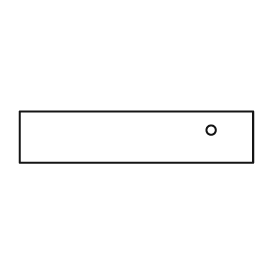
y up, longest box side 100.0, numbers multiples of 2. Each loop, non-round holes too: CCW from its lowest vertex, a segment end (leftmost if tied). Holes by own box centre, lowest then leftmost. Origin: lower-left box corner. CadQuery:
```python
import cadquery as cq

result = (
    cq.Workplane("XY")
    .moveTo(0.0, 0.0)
    .lineTo(100.0, 0.0)
    .lineTo(100.0, 22.0)
    .lineTo(0.0, 22.0)
    .close()
    .moveTo(82.0, 14.0)
    .circle(2.0)
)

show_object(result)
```